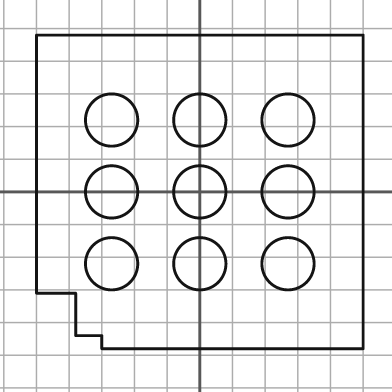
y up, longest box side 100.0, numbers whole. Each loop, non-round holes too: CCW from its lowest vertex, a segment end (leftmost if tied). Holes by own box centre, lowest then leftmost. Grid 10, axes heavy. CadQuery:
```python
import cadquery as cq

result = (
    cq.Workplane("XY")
    .moveTo(-30.0, -48.0)
    .lineTo(50.0, -48.0)
    .lineTo(50.0, 48.0)
    .lineTo(-50.0, 48.0)
    .lineTo(-50.0, -31.0)
    .lineTo(-38.0, -31.0)
    .lineTo(-38.0, -44.0)
    .lineTo(-30.0, -44.0)
    .close()
    .moveTo(-27.0, -22.0)
    .circle(8.0)
    .moveTo(0.0, -22.0)
    .circle(8.0)
    .moveTo(27.0, -22.0)
    .circle(8.0)
    .moveTo(-27.0, 0.0)
    .circle(8.0)
    .moveTo(0.0, 0.0)
    .circle(8.0)
    .moveTo(27.0, 0.0)
    .circle(8.0)
    .moveTo(-27.0, 22.0)
    .circle(8.0)
    .moveTo(0.0, 22.0)
    .circle(8.0)
    .moveTo(27.0, 22.0)
    .circle(8.0)
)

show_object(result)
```